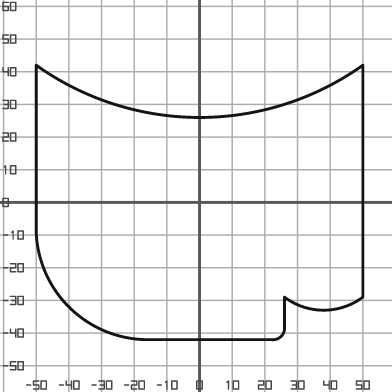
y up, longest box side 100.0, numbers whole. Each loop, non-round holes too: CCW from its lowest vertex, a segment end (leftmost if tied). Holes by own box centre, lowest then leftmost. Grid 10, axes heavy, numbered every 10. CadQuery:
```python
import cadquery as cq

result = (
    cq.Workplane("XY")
    .moveTo(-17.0, -42.0)
    .lineTo(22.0, -42.0)
    .threePointArc((25.0, -41.0), (26.0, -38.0))
    .lineTo(26.0, -29.0)
    .threePointArc((38.0, -33.0), (50.0, -29.0))
    .lineTo(50.0, 42.0)
    .threePointArc((0.0, 26.0), (-50.0, 42.0))
    .lineTo(-50.0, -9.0)
    .threePointArc((-40.0, -32.0), (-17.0, -42.0))
    .close()
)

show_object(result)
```